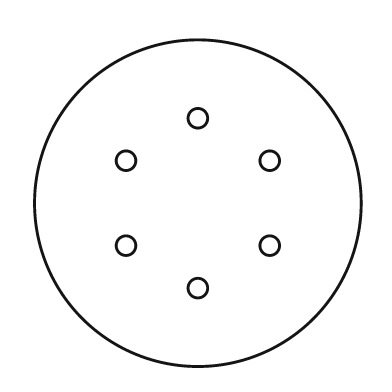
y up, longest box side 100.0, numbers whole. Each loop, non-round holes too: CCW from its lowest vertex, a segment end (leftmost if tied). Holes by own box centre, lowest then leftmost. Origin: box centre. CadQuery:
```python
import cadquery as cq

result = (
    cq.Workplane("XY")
    .moveTo(0.0, 0.0)
    .circle(50.0)
    .moveTo(0.0, -26.0)
    .circle(3.0)
    .moveTo(-22.0, -13.0)
    .circle(3.0)
    .moveTo(22.0, -13.0)
    .circle(3.0)
    .moveTo(-22.0, 13.0)
    .circle(3.0)
    .moveTo(22.0, 13.0)
    .circle(3.0)
    .moveTo(0.0, 26.0)
    .circle(3.0)
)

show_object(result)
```